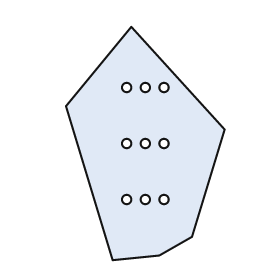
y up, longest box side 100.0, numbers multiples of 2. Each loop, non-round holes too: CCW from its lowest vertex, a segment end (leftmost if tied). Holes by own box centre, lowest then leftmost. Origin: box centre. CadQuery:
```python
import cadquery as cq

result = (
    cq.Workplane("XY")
    .moveTo(-14.0, -50.0)
    .lineTo(6.0, -48.0)
    .lineTo(20.0, -40.0)
    .lineTo(34.0, 6.0)
    .lineTo(-6.0, 50.0)
    .lineTo(-34.0, 16.0)
    .close()
    .moveTo(-8.0, -24.0)
    .circle(2.0)
    .moveTo(0.0, -24.0)
    .circle(2.0)
    .moveTo(8.0, -24.0)
    .circle(2.0)
    .moveTo(-8.0, 0.0)
    .circle(2.0)
    .moveTo(0.0, 0.0)
    .circle(2.0)
    .moveTo(8.0, 0.0)
    .circle(2.0)
    .moveTo(-8.0, 24.0)
    .circle(2.0)
    .moveTo(0.0, 24.0)
    .circle(2.0)
    .moveTo(8.0, 24.0)
    .circle(2.0)
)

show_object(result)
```